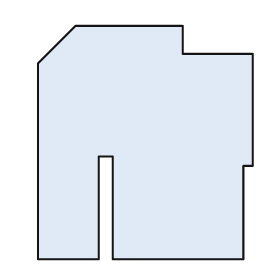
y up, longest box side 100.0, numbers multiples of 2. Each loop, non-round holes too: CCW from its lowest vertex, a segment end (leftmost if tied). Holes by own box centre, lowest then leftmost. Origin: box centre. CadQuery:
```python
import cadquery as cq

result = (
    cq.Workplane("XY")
    .moveTo(-46.0, -50.0)
    .lineTo(-20.0, -50.0)
    .lineTo(-20.0, -6.0)
    .lineTo(-14.0, -6.0)
    .lineTo(-14.0, -50.0)
    .lineTo(42.0, -50.0)
    .lineTo(42.0, -10.0)
    .lineTo(46.0, -10.0)
    .lineTo(46.0, 38.0)
    .lineTo(16.0, 38.0)
    .lineTo(16.0, 50.0)
    .lineTo(-30.0, 50.0)
    .lineTo(-46.0, 34.0)
    .close()
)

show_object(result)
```